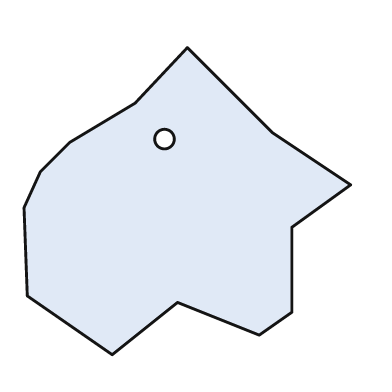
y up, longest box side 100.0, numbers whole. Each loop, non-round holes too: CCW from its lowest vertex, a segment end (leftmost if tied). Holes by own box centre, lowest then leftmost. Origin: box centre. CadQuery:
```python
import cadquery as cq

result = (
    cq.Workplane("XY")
    .moveTo(-23.0, -47.0)
    .lineTo(-3.0, -31.0)
    .lineTo(22.0, -41.0)
    .lineTo(32.0, -34.0)
    .lineTo(32.0, -8.0)
    .lineTo(50.0, 5.0)
    .lineTo(26.0, 21.0)
    .lineTo(0.0, 47.0)
    .lineTo(-16.0, 30.0)
    .lineTo(-36.0, 18.0)
    .lineTo(-45.0, 9.0)
    .lineTo(-50.0, -2.0)
    .lineTo(-49.0, -29.0)
    .close()
    .moveTo(-7.0, 19.0)
    .circle(3.0)
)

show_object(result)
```